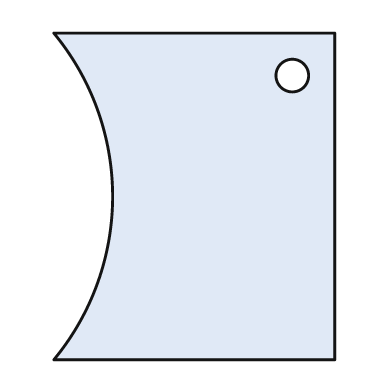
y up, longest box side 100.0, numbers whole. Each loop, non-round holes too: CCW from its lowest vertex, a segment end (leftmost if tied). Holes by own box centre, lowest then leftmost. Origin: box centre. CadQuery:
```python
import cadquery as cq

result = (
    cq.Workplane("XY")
    .moveTo(-43.0, -50.0)
    .lineTo(43.0, -50.0)
    .lineTo(43.0, 50.0)
    .lineTo(-43.0, 50.0)
    .threePointArc((-25.0, 0.0), (-43.0, -50.0))
    .close()
    .moveTo(30.0, 37.0)
    .circle(5.0)
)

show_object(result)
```